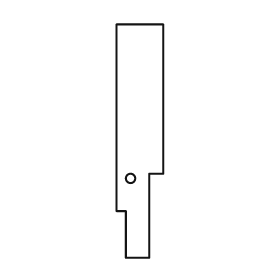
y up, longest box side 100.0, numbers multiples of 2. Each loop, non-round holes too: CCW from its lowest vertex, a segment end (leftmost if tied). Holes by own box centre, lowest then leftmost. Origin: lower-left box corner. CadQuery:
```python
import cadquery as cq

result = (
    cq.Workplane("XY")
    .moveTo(4.0, 0.0)
    .lineTo(14.0, 0.0)
    .lineTo(14.0, 36.0)
    .lineTo(20.0, 36.0)
    .lineTo(20.0, 100.0)
    .lineTo(0.0, 100.0)
    .lineTo(0.0, 20.0)
    .lineTo(4.0, 20.0)
    .close()
    .moveTo(6.0, 34.0)
    .circle(2.0)
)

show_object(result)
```